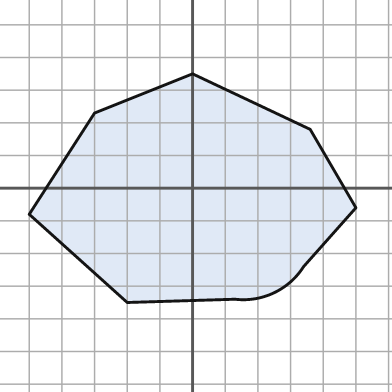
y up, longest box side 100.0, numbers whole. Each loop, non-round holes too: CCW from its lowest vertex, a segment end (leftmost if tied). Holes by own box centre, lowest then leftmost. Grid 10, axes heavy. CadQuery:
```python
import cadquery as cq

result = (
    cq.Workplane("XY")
    .moveTo(-20.0, -35.0)
    .lineTo(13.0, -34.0)
    .threePointArc((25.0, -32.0), (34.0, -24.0))
    .lineTo(50.0, -6.0)
    .lineTo(36.0, 18.0)
    .lineTo(0.0, 35.0)
    .lineTo(-30.0, 23.0)
    .lineTo(-50.0, -8.0)
    .close()
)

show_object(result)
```